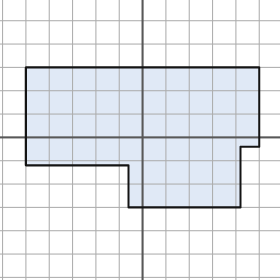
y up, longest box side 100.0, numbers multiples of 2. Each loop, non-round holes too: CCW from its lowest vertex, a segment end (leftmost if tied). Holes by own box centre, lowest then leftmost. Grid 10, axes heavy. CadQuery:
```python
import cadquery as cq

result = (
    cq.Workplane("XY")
    .moveTo(-6.0, -30.0)
    .lineTo(42.0, -30.0)
    .lineTo(42.0, -4.0)
    .lineTo(50.0, -4.0)
    .lineTo(50.0, 30.0)
    .lineTo(-50.0, 30.0)
    .lineTo(-50.0, -12.0)
    .lineTo(-6.0, -12.0)
    .close()
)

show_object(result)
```